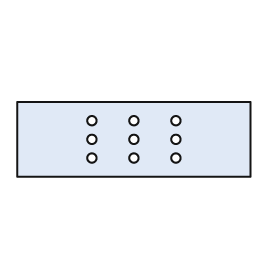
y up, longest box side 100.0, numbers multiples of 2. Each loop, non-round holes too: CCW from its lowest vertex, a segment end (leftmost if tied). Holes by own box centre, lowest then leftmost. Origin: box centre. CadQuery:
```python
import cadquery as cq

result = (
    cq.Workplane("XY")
    .moveTo(-50.0, -16.0)
    .lineTo(50.0, -16.0)
    .lineTo(50.0, 16.0)
    .lineTo(-50.0, 16.0)
    .close()
    .moveTo(-18.0, -8.0)
    .circle(2.0)
    .moveTo(0.0, -8.0)
    .circle(2.0)
    .moveTo(18.0, -8.0)
    .circle(2.0)
    .moveTo(-18.0, 0.0)
    .circle(2.0)
    .moveTo(0.0, 0.0)
    .circle(2.0)
    .moveTo(18.0, 0.0)
    .circle(2.0)
    .moveTo(-18.0, 8.0)
    .circle(2.0)
    .moveTo(0.0, 8.0)
    .circle(2.0)
    .moveTo(18.0, 8.0)
    .circle(2.0)
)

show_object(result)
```